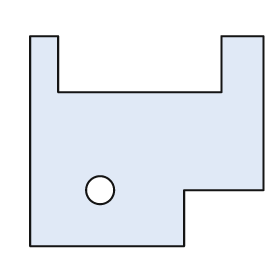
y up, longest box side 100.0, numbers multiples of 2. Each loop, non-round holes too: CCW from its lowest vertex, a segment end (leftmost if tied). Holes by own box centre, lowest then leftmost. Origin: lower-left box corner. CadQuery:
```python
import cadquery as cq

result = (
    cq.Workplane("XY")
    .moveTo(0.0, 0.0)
    .lineTo(66.0, 0.0)
    .lineTo(66.0, 24.0)
    .lineTo(100.0, 24.0)
    .lineTo(100.0, 90.0)
    .lineTo(82.0, 90.0)
    .lineTo(82.0, 66.0)
    .lineTo(12.0, 66.0)
    .lineTo(12.0, 90.0)
    .lineTo(0.0, 90.0)
    .close()
    .moveTo(30.0, 24.0)
    .circle(6.0)
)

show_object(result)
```